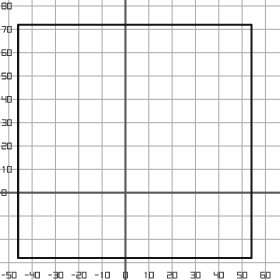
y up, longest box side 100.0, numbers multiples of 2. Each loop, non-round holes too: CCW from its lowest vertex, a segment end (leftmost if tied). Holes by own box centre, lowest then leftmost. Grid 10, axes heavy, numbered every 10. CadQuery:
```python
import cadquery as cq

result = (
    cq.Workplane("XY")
    .moveTo(-46.0, -28.0)
    .lineTo(54.0, -28.0)
    .lineTo(54.0, 72.0)
    .lineTo(-46.0, 72.0)
    .close()
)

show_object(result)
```